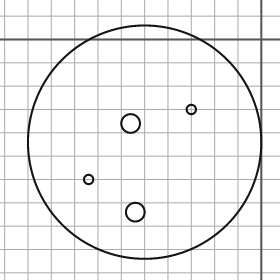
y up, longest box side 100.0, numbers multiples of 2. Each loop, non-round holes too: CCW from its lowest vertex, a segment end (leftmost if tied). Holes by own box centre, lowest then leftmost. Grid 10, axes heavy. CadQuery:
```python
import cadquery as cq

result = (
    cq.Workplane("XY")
    .moveTo(-50.0, -44.0)
    .circle(50.0)
    .moveTo(-54.0, -74.0)
    .circle(4.0)
    .moveTo(-74.0, -60.0)
    .circle(2.0)
    .moveTo(-56.0, -36.0)
    .circle(4.0)
    .moveTo(-30.0, -30.0)
    .circle(2.0)
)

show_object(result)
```